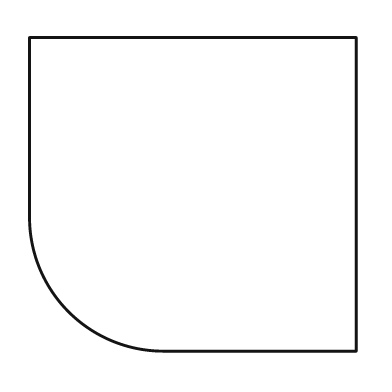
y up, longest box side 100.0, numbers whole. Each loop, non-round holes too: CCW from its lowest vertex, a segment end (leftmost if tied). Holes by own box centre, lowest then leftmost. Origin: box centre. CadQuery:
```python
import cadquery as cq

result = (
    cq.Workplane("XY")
    .moveTo(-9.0, -48.0)
    .lineTo(50.0, -48.0)
    .lineTo(50.0, 48.0)
    .lineTo(-50.0, 48.0)
    .lineTo(-50.0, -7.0)
    .threePointArc((-38.0, -36.0), (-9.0, -48.0))
    .close()
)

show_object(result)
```